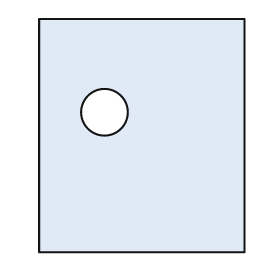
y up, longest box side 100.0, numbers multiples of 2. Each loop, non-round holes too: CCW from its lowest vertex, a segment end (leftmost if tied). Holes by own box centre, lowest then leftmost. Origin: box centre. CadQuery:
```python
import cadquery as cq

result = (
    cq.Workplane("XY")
    .moveTo(-44.0, -50.0)
    .lineTo(44.0, -50.0)
    .lineTo(44.0, 50.0)
    .lineTo(-44.0, 50.0)
    .close()
    .moveTo(-16.0, 10.0)
    .circle(10.0)
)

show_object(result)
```